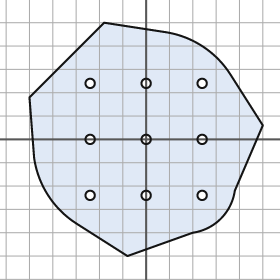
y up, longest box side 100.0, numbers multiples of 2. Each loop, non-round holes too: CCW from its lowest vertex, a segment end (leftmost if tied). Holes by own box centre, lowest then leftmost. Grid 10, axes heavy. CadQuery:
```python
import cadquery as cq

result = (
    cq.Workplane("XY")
    .moveTo(-8.0, -50.0)
    .lineTo(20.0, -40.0)
    .threePointArc((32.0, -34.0), (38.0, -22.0))
    .lineTo(50.0, 6.0)
    .lineTo(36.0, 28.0)
    .threePointArc((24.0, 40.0), (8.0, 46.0))
    .lineTo(-18.0, 50.0)
    .lineTo(-50.0, 18.0)
    .lineTo(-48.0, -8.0)
    .threePointArc((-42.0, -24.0), (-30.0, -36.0))
    .close()
    .moveTo(-24.0, -24.0)
    .circle(2.0)
    .moveTo(0.0, -24.0)
    .circle(2.0)
    .moveTo(24.0, -24.0)
    .circle(2.0)
    .moveTo(-24.0, 0.0)
    .circle(2.0)
    .moveTo(0.0, 0.0)
    .circle(2.0)
    .moveTo(24.0, 0.0)
    .circle(2.0)
    .moveTo(-24.0, 24.0)
    .circle(2.0)
    .moveTo(0.0, 24.0)
    .circle(2.0)
    .moveTo(24.0, 24.0)
    .circle(2.0)
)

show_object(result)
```